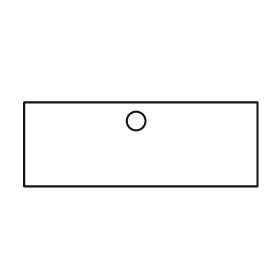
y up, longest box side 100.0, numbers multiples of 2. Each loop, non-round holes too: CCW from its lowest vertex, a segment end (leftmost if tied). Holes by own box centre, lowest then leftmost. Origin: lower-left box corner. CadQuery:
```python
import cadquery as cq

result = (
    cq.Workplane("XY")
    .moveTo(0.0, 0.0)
    .lineTo(100.0, 0.0)
    .lineTo(100.0, 36.0)
    .lineTo(0.0, 36.0)
    .close()
    .moveTo(48.0, 28.0)
    .circle(4.0)
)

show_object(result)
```